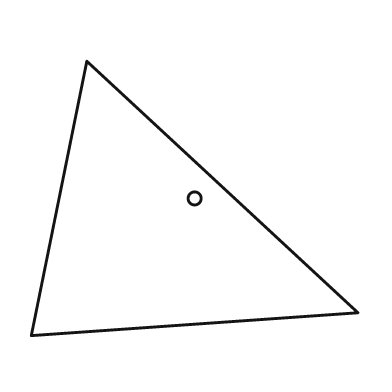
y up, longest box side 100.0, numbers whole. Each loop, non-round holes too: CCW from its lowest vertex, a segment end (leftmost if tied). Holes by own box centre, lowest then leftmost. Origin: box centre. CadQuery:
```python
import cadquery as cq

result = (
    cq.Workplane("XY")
    .moveTo(-50.0, -42.0)
    .lineTo(50.0, -35.0)
    .lineTo(-33.0, 42.0)
    .close()
    .moveTo(0.0, 0.0)
    .circle(2.0)
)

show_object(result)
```